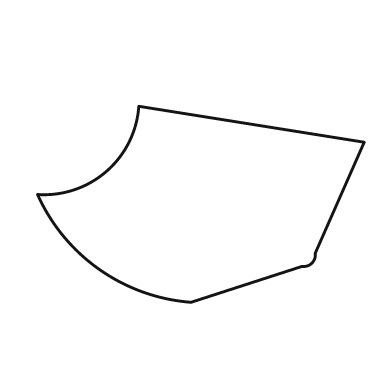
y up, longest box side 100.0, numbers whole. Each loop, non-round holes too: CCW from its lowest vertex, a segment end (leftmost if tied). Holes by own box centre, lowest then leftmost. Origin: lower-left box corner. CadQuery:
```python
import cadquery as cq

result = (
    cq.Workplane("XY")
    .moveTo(47.0, 0.0)
    .lineTo(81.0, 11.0)
    .threePointArc((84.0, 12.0), (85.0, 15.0))
    .lineTo(100.0, 49.0)
    .lineTo(31.0, 60.0)
    .threePointArc((21.0, 40.0), (0.0, 33.0))
    .threePointArc((19.0, 10.0), (47.0, 0.0))
    .close()
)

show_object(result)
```